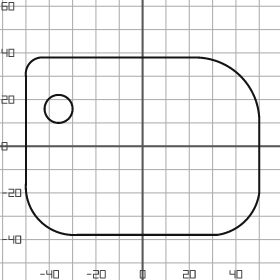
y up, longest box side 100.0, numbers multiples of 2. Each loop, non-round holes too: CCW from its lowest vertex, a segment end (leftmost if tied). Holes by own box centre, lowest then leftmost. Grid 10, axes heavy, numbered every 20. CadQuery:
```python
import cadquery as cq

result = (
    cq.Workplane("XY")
    .moveTo(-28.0, -38.0)
    .lineTo(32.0, -38.0)
    .threePointArc((44.0, -32.0), (50.0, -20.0))
    .lineTo(50.0, 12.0)
    .threePointArc((42.0, 30.0), (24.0, 38.0))
    .lineTo(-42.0, 38.0)
    .threePointArc((-48.0, 36.0), (-50.0, 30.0))
    .lineTo(-50.0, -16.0)
    .threePointArc((-44.0, -32.0), (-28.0, -38.0))
    .close()
    .moveTo(-36.0, 16.0)
    .circle(6.0)
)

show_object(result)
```